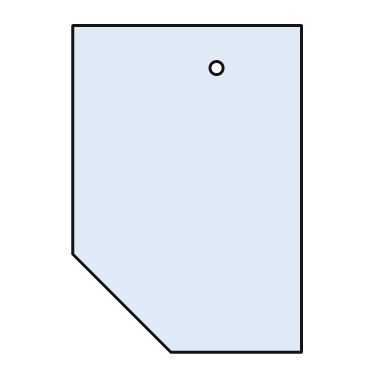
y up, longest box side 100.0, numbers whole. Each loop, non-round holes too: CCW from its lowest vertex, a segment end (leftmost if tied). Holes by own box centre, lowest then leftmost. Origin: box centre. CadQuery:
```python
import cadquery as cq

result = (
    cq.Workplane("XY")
    .moveTo(-5.0, -50.0)
    .lineTo(35.0, -50.0)
    .lineTo(35.0, 50.0)
    .lineTo(-35.0, 50.0)
    .lineTo(-35.0, -20.0)
    .close()
    .moveTo(9.0, 37.0)
    .circle(2.0)
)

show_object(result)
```